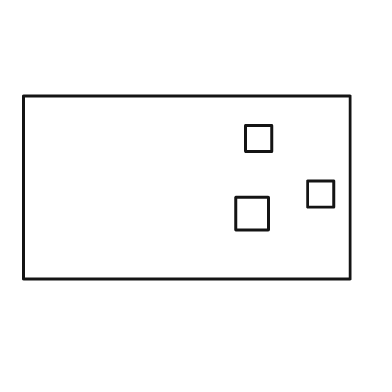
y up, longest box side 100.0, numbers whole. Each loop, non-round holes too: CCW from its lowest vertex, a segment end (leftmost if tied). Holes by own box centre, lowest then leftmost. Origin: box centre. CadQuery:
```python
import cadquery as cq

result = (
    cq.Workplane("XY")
    .moveTo(-50.0, -28.0)
    .lineTo(50.0, -28.0)
    .lineTo(50.0, 28.0)
    .lineTo(-50.0, 28.0)
    .close()
    .moveTo(15.0, -13.0)
    .lineTo(25.0, -13.0)
    .lineTo(25.0, -3.0)
    .lineTo(15.0, -3.0)
    .close()
    .moveTo(37.0, -6.0)
    .lineTo(45.0, -6.0)
    .lineTo(45.0, 2.0)
    .lineTo(37.0, 2.0)
    .close()
    .moveTo(18.0, 11.0)
    .lineTo(26.0, 11.0)
    .lineTo(26.0, 19.0)
    .lineTo(18.0, 19.0)
    .close()
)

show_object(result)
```